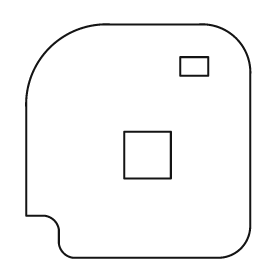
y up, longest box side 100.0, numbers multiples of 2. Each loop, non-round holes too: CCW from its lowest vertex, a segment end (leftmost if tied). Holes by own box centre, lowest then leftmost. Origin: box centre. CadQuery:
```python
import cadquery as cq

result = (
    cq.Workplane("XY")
    .moveTo(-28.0, -50.0)
    .lineTo(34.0, -50.0)
    .threePointArc((44.0, -46.0), (48.0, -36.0))
    .lineTo(48.0, 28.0)
    .threePointArc((42.0, 44.0), (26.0, 50.0))
    .lineTo(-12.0, 50.0)
    .threePointArc((-38.0, 40.0), (-48.0, 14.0))
    .lineTo(-48.0, -32.0)
    .lineTo(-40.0, -32.0)
    .threePointArc((-36.0, -34.0), (-34.0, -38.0))
    .lineTo(-34.0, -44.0)
    .threePointArc((-32.0, -48.0), (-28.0, -50.0))
    .close()
    .moveTo(-6.0, -16.0)
    .lineTo(14.0, -16.0)
    .lineTo(14.0, 4.0)
    .lineTo(-6.0, 4.0)
    .close()
    .moveTo(18.0, 28.0)
    .lineTo(30.0, 28.0)
    .lineTo(30.0, 36.0)
    .lineTo(18.0, 36.0)
    .close()
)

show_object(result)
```